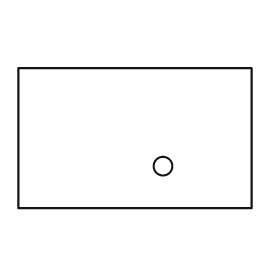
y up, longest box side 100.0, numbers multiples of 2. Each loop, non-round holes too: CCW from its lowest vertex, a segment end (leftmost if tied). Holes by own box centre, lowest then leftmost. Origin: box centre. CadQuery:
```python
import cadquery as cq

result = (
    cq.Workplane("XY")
    .moveTo(-50.0, -30.0)
    .lineTo(50.0, -30.0)
    .lineTo(50.0, 30.0)
    .lineTo(-50.0, 30.0)
    .close()
    .moveTo(12.0, -12.0)
    .circle(4.0)
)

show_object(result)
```